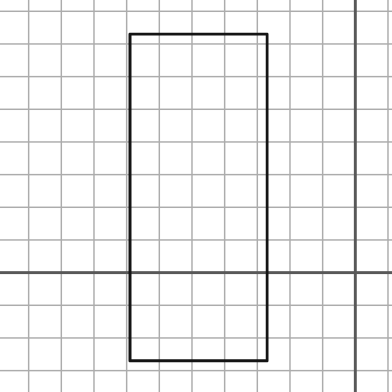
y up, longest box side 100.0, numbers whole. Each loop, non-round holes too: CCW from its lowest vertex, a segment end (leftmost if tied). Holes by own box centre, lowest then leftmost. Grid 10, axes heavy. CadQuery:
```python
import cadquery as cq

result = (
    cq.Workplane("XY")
    .moveTo(-69.0, -27.0)
    .lineTo(-27.0, -27.0)
    .lineTo(-27.0, 73.0)
    .lineTo(-69.0, 73.0)
    .close()
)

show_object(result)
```